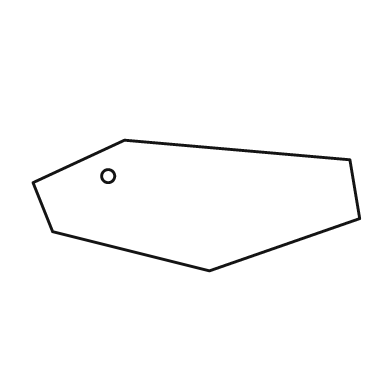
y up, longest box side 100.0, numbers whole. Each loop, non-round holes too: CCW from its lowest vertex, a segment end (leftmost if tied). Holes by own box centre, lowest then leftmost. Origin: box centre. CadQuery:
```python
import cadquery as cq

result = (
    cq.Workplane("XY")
    .moveTo(4.0, -20.0)
    .lineTo(50.0, -4.0)
    .lineTo(47.0, 14.0)
    .lineTo(-22.0, 20.0)
    .lineTo(-50.0, 7.0)
    .lineTo(-44.0, -8.0)
    .close()
    .moveTo(-27.0, 9.0)
    .circle(2.0)
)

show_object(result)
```